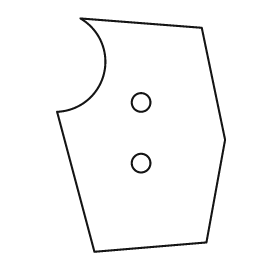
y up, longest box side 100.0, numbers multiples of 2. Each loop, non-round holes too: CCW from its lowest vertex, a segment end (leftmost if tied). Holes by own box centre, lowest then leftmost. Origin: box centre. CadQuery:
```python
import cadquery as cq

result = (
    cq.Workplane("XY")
    .moveTo(-20.0, -50.0)
    .lineTo(28.0, -46.0)
    .lineTo(36.0, -2.0)
    .lineTo(26.0, 46.0)
    .lineTo(-26.0, 50.0)
    .threePointArc((-16.0, 26.0), (-36.0, 10.0))
    .close()
    .moveTo(0.0, -12.0)
    .circle(4.0)
    .moveTo(0.0, 14.0)
    .circle(4.0)
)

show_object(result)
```